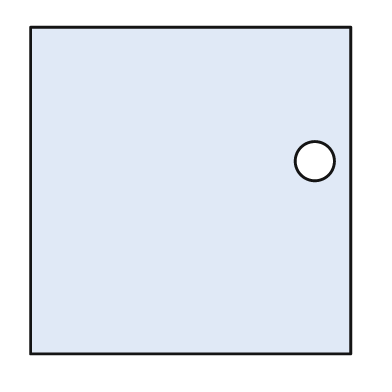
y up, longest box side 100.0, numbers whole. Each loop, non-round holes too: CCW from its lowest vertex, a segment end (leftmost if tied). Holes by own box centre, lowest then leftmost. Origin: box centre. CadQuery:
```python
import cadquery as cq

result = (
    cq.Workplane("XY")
    .moveTo(-49.0, -50.0)
    .lineTo(49.0, -50.0)
    .lineTo(49.0, 50.0)
    .lineTo(-49.0, 50.0)
    .close()
    .moveTo(38.0, 9.0)
    .circle(6.0)
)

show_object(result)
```